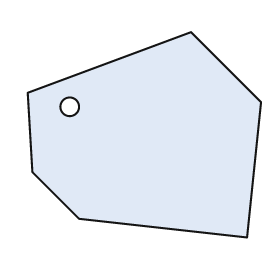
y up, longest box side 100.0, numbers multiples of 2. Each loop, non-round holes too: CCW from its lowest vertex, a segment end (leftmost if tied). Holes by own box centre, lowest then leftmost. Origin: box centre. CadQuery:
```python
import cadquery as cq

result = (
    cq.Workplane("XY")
    .moveTo(44.0, -44.0)
    .lineTo(50.0, 14.0)
    .lineTo(20.0, 44.0)
    .lineTo(-50.0, 18.0)
    .lineTo(-48.0, -16.0)
    .lineTo(-28.0, -36.0)
    .close()
    .moveTo(-32.0, 12.0)
    .circle(4.0)
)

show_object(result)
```